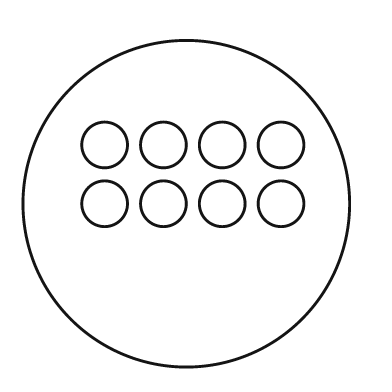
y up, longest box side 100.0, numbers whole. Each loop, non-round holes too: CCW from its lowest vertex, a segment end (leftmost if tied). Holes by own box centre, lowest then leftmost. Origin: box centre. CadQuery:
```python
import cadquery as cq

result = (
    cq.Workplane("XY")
    .moveTo(0.0, 0.0)
    .circle(50.0)
    .moveTo(-25.0, 0.0)
    .circle(7.0)
    .moveTo(-7.0, 0.0)
    .circle(7.0)
    .moveTo(11.0, 0.0)
    .circle(7.0)
    .moveTo(29.0, 0.0)
    .circle(7.0)
    .moveTo(-25.0, 18.0)
    .circle(7.0)
    .moveTo(-7.0, 18.0)
    .circle(7.0)
    .moveTo(11.0, 18.0)
    .circle(7.0)
    .moveTo(29.0, 18.0)
    .circle(7.0)
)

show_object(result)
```